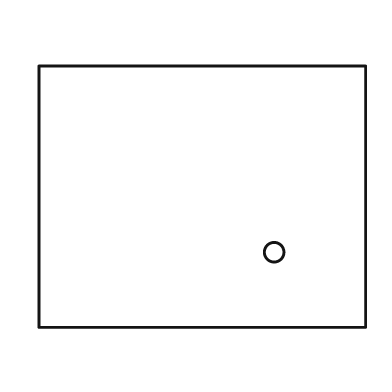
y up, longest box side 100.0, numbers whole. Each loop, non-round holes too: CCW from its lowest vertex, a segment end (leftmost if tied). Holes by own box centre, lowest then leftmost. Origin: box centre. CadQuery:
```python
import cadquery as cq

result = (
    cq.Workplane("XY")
    .moveTo(-50.0, -40.0)
    .lineTo(50.0, -40.0)
    .lineTo(50.0, 40.0)
    .lineTo(-50.0, 40.0)
    .close()
    .moveTo(22.0, -17.0)
    .circle(3.0)
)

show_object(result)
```